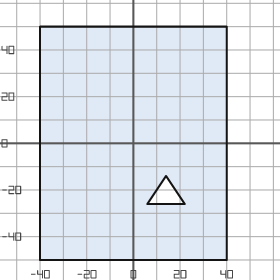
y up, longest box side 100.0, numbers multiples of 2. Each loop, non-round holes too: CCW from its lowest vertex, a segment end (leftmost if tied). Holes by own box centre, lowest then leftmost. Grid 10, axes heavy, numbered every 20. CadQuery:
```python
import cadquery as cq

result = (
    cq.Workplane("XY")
    .moveTo(-40.0, -50.0)
    .lineTo(40.0, -50.0)
    .lineTo(40.0, 50.0)
    .lineTo(-40.0, 50.0)
    .close()
    .moveTo(6.0, -26.0)
    .lineTo(22.0, -26.0)
    .lineTo(14.0, -14.0)
    .close()
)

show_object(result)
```